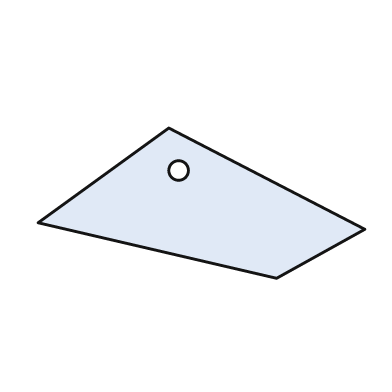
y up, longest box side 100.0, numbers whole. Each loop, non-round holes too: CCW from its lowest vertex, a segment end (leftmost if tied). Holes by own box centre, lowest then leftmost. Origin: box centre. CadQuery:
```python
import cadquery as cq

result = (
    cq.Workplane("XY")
    .moveTo(23.0, -23.0)
    .lineTo(50.0, -8.0)
    .lineTo(-10.0, 23.0)
    .lineTo(-50.0, -6.0)
    .close()
    .moveTo(-7.0, 10.0)
    .circle(3.0)
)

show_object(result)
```